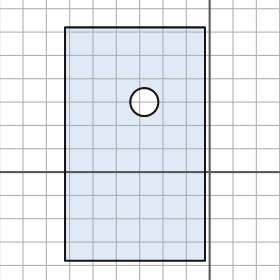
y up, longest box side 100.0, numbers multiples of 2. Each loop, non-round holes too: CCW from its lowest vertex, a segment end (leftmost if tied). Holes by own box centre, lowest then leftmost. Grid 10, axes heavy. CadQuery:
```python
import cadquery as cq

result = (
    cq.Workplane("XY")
    .moveTo(-62.0, -38.0)
    .lineTo(-2.0, -38.0)
    .lineTo(-2.0, 62.0)
    .lineTo(-62.0, 62.0)
    .close()
    .moveTo(-28.0, 30.0)
    .circle(6.0)
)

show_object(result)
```